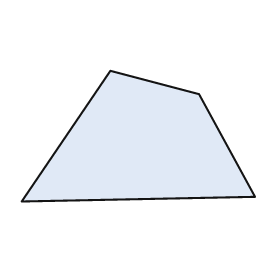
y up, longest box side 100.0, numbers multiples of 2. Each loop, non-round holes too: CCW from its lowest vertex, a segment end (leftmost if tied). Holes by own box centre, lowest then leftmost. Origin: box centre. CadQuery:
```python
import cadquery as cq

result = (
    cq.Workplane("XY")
    .moveTo(-50.0, -28.0)
    .lineTo(50.0, -26.0)
    .lineTo(26.0, 18.0)
    .lineTo(-12.0, 28.0)
    .close()
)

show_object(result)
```